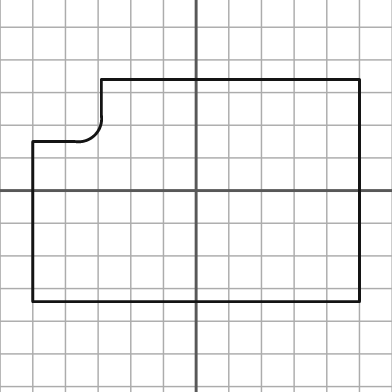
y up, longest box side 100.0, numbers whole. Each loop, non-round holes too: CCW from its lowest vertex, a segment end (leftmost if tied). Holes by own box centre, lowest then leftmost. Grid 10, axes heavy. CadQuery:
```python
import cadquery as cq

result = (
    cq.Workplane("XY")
    .moveTo(-50.0, -34.0)
    .lineTo(50.0, -34.0)
    .lineTo(50.0, 34.0)
    .lineTo(-29.0, 34.0)
    .lineTo(-29.0, 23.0)
    .threePointArc((-31.0, 17.0), (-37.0, 15.0))
    .lineTo(-50.0, 15.0)
    .close()
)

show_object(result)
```